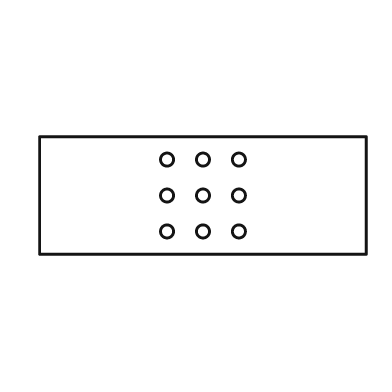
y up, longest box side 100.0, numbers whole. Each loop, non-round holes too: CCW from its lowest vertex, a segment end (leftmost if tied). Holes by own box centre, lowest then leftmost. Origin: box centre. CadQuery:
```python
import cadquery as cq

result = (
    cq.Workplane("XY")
    .moveTo(-50.0, -18.0)
    .lineTo(50.0, -18.0)
    .lineTo(50.0, 18.0)
    .lineTo(-50.0, 18.0)
    .close()
    .moveTo(-11.0, -11.0)
    .circle(2.0)
    .moveTo(0.0, -11.0)
    .circle(2.0)
    .moveTo(11.0, -11.0)
    .circle(2.0)
    .moveTo(-11.0, 0.0)
    .circle(2.0)
    .moveTo(0.0, 0.0)
    .circle(2.0)
    .moveTo(11.0, 0.0)
    .circle(2.0)
    .moveTo(-11.0, 11.0)
    .circle(2.0)
    .moveTo(0.0, 11.0)
    .circle(2.0)
    .moveTo(11.0, 11.0)
    .circle(2.0)
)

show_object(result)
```